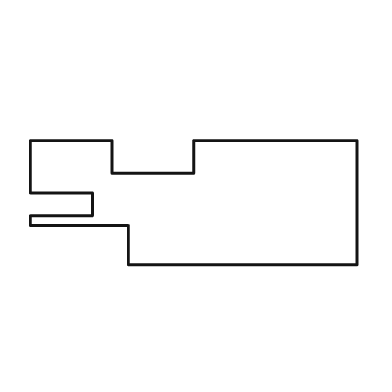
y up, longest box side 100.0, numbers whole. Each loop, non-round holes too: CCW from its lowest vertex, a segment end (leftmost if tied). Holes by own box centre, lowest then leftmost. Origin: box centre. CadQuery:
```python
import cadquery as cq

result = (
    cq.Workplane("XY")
    .moveTo(-20.0, -19.0)
    .lineTo(50.0, -19.0)
    .lineTo(50.0, 19.0)
    .lineTo(0.0, 19.0)
    .lineTo(0.0, 9.0)
    .lineTo(-25.0, 9.0)
    .lineTo(-25.0, 19.0)
    .lineTo(-50.0, 19.0)
    .lineTo(-50.0, 3.0)
    .lineTo(-31.0, 3.0)
    .lineTo(-31.0, -4.0)
    .lineTo(-50.0, -4.0)
    .lineTo(-50.0, -7.0)
    .lineTo(-20.0, -7.0)
    .close()
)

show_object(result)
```